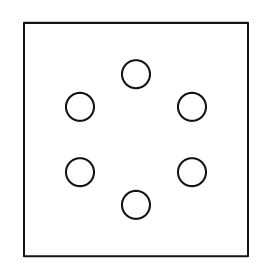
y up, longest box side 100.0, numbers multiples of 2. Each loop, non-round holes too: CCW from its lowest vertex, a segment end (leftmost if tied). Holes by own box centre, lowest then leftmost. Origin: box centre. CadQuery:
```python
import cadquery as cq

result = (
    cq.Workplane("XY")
    .moveTo(-48.0, -50.0)
    .lineTo(48.0, -50.0)
    .lineTo(48.0, 50.0)
    .lineTo(-48.0, 50.0)
    .close()
    .moveTo(0.0, -28.0)
    .circle(6.0)
    .moveTo(-24.0, -14.0)
    .circle(6.0)
    .moveTo(24.0, -14.0)
    .circle(6.0)
    .moveTo(-24.0, 14.0)
    .circle(6.0)
    .moveTo(24.0, 14.0)
    .circle(6.0)
    .moveTo(0.0, 28.0)
    .circle(6.0)
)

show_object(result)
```